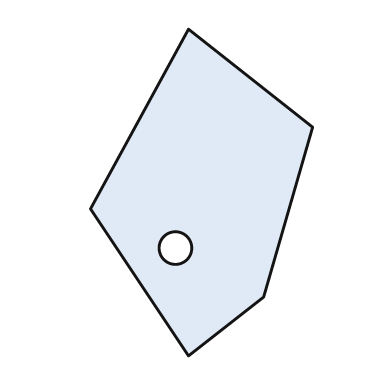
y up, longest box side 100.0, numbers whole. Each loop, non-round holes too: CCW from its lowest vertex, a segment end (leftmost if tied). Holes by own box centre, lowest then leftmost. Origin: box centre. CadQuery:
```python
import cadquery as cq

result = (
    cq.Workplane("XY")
    .moveTo(-4.0, -50.0)
    .lineTo(19.0, -32.0)
    .lineTo(34.0, 20.0)
    .lineTo(-4.0, 50.0)
    .lineTo(-34.0, -5.0)
    .close()
    .moveTo(-8.0, -17.0)
    .circle(5.0)
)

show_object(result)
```